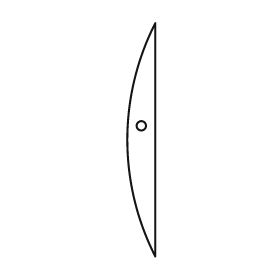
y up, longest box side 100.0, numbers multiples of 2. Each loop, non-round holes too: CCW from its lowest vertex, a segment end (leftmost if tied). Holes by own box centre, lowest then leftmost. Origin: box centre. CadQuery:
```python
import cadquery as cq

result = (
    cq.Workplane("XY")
    .moveTo(6.0, -50.0)
    .lineTo(6.0, 50.0)
    .threePointArc((-6.0, 0.0), (6.0, -50.0))
    .close()
    .moveTo(0.0, 6.0)
    .circle(2.0)
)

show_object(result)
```